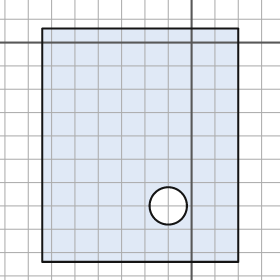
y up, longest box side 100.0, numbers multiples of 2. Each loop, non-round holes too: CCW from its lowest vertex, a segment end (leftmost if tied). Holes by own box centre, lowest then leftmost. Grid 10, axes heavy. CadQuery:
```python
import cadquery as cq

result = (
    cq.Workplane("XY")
    .moveTo(-64.0, -94.0)
    .lineTo(20.0, -94.0)
    .lineTo(20.0, 6.0)
    .lineTo(-64.0, 6.0)
    .close()
    .moveTo(-10.0, -70.0)
    .circle(8.0)
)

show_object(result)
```